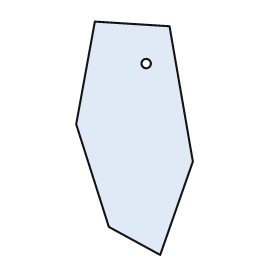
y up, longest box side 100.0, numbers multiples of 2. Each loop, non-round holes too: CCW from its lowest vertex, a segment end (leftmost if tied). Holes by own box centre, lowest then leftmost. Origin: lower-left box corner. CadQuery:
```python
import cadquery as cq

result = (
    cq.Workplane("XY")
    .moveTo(36.0, 0.0)
    .lineTo(50.0, 40.0)
    .lineTo(40.0, 98.0)
    .lineTo(8.0, 100.0)
    .lineTo(0.0, 56.0)
    .lineTo(14.0, 12.0)
    .close()
    .moveTo(30.0, 82.0)
    .circle(2.0)
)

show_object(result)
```